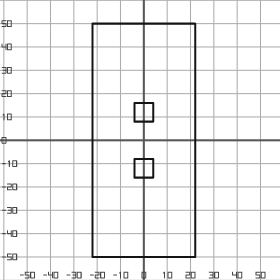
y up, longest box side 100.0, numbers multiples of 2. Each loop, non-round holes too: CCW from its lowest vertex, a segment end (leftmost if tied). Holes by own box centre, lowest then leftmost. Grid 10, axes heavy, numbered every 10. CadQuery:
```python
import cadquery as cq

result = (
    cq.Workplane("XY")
    .moveTo(-22.0, -50.0)
    .lineTo(22.0, -50.0)
    .lineTo(22.0, 50.0)
    .lineTo(-22.0, 50.0)
    .close()
    .moveTo(-4.0, -16.0)
    .lineTo(4.0, -16.0)
    .lineTo(4.0, -8.0)
    .lineTo(-4.0, -8.0)
    .close()
    .moveTo(-4.0, 8.0)
    .lineTo(4.0, 8.0)
    .lineTo(4.0, 16.0)
    .lineTo(-4.0, 16.0)
    .close()
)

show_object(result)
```